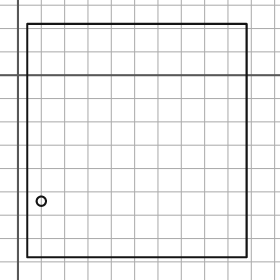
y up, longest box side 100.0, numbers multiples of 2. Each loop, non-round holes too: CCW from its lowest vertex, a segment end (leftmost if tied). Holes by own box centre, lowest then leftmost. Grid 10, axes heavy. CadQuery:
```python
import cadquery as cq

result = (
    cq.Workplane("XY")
    .moveTo(4.0, -78.0)
    .lineTo(98.0, -78.0)
    .lineTo(98.0, 22.0)
    .lineTo(4.0, 22.0)
    .close()
    .moveTo(10.0, -54.0)
    .circle(2.0)
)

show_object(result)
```